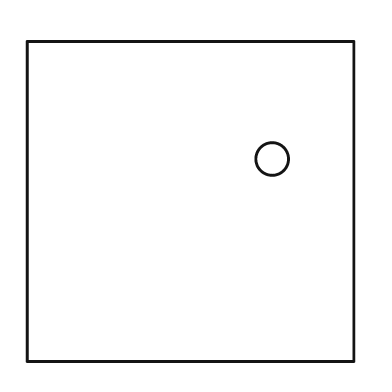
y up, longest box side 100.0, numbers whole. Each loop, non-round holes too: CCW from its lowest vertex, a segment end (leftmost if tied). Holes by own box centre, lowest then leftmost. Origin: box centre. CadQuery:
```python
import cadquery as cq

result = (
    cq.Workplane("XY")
    .moveTo(-50.0, -49.0)
    .lineTo(50.0, -49.0)
    .lineTo(50.0, 49.0)
    .lineTo(-50.0, 49.0)
    .close()
    .moveTo(25.0, 13.0)
    .circle(5.0)
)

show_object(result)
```